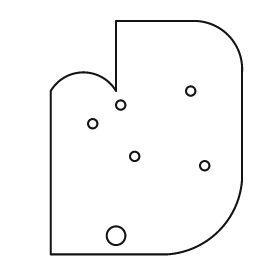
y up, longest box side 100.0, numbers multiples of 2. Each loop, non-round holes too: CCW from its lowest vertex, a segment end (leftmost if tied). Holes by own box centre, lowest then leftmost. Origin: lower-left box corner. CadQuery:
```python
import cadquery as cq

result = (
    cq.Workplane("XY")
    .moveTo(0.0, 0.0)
    .lineTo(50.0, 0.0)
    .threePointArc((72.0, 10.0), (82.0, 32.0))
    .lineTo(82.0, 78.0)
    .threePointArc((76.0, 94.0), (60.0, 100.0))
    .lineTo(28.0, 100.0)
    .lineTo(28.0, 70.0)
    .threePointArc((14.0, 78.0), (0.0, 70.0))
    .close()
    .moveTo(28.0, 8.0)
    .circle(4.0)
    .moveTo(66.0, 38.0)
    .circle(2.0)
    .moveTo(36.0, 42.0)
    .circle(2.0)
    .moveTo(18.0, 56.0)
    .circle(2.0)
    .moveTo(30.0, 64.0)
    .circle(2.0)
    .moveTo(60.0, 70.0)
    .circle(2.0)
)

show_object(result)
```